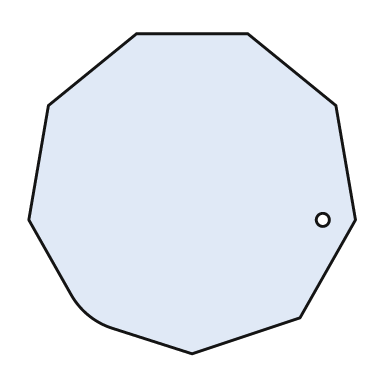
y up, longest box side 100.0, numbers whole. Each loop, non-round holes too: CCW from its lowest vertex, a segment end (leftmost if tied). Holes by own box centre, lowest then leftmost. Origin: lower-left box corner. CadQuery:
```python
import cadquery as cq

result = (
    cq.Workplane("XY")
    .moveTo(50.0, 0.0)
    .lineTo(83.0, 11.0)
    .lineTo(100.0, 41.0)
    .lineTo(94.0, 76.0)
    .lineTo(67.0, 98.0)
    .lineTo(33.0, 98.0)
    .lineTo(6.0, 76.0)
    .lineTo(0.0, 41.0)
    .lineTo(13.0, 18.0)
    .threePointArc((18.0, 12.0), (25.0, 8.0))
    .close()
    .moveTo(90.0, 41.0)
    .circle(2.0)
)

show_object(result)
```